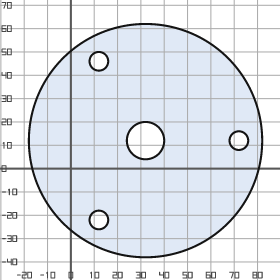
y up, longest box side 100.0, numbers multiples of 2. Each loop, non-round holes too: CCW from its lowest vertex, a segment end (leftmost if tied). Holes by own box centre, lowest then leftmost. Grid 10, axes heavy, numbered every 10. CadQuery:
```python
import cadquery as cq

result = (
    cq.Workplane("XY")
    .moveTo(32.0, 12.0)
    .circle(50.0)
    .moveTo(12.0, -22.0)
    .circle(4.0)
    .moveTo(32.0, 12.0)
    .circle(8.0)
    .moveTo(72.0, 12.0)
    .circle(4.0)
    .moveTo(12.0, 46.0)
    .circle(4.0)
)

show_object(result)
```